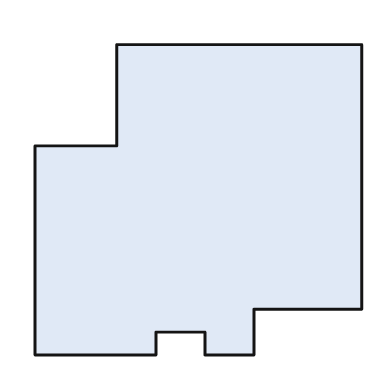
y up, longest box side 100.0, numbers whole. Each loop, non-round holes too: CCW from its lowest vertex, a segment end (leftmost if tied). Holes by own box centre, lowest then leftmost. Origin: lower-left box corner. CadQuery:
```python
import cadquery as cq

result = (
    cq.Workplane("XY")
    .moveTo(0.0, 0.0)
    .lineTo(37.0, 0.0)
    .lineTo(37.0, 7.0)
    .lineTo(52.0, 7.0)
    .lineTo(52.0, 0.0)
    .lineTo(67.0, 0.0)
    .lineTo(67.0, 14.0)
    .lineTo(100.0, 14.0)
    .lineTo(100.0, 95.0)
    .lineTo(25.0, 95.0)
    .lineTo(25.0, 64.0)
    .lineTo(0.0, 64.0)
    .close()
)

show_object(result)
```